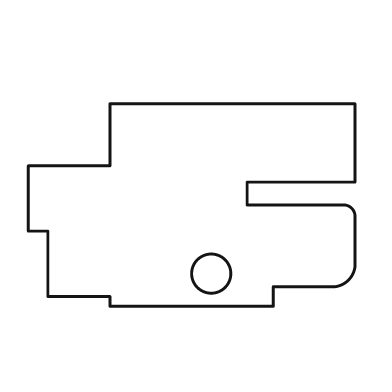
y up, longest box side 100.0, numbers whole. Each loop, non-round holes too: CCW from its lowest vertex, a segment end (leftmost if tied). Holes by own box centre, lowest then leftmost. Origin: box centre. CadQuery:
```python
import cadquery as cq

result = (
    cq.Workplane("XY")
    .moveTo(-25.0, -31.0)
    .lineTo(25.0, -31.0)
    .lineTo(25.0, -25.0)
    .lineTo(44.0, -25.0)
    .threePointArc((48.0, -23.0), (50.0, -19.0))
    .lineTo(50.0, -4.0)
    .threePointArc((49.0, -1.0), (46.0, 0.0))
    .lineTo(17.0, 0.0)
    .lineTo(17.0, 7.0)
    .lineTo(50.0, 7.0)
    .lineTo(50.0, 31.0)
    .lineTo(-25.0, 31.0)
    .lineTo(-25.0, 12.0)
    .lineTo(-50.0, 12.0)
    .lineTo(-50.0, -8.0)
    .lineTo(-44.0, -8.0)
    .lineTo(-44.0, -28.0)
    .lineTo(-25.0, -28.0)
    .close()
    .moveTo(6.0, -21.0)
    .circle(6.0)
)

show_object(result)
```